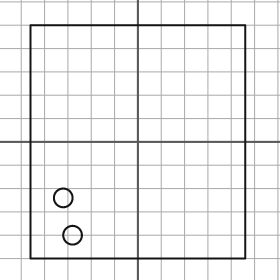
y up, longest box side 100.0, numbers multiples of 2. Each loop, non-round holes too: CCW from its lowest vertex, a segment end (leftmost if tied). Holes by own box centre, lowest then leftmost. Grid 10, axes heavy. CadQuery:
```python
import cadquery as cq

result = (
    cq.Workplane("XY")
    .moveTo(-46.0, -50.0)
    .lineTo(46.0, -50.0)
    .lineTo(46.0, 50.0)
    .lineTo(-46.0, 50.0)
    .close()
    .moveTo(-28.0, -40.0)
    .circle(4.0)
    .moveTo(-32.0, -24.0)
    .circle(4.0)
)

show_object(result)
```